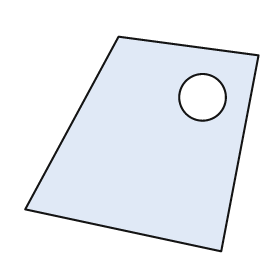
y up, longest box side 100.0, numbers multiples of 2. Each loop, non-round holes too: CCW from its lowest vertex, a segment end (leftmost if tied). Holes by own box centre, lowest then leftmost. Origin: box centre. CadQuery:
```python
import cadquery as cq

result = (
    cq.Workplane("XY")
    .moveTo(34.0, -46.0)
    .lineTo(50.0, 38.0)
    .lineTo(-10.0, 46.0)
    .lineTo(-50.0, -28.0)
    .close()
    .moveTo(26.0, 20.0)
    .circle(10.0)
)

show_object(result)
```